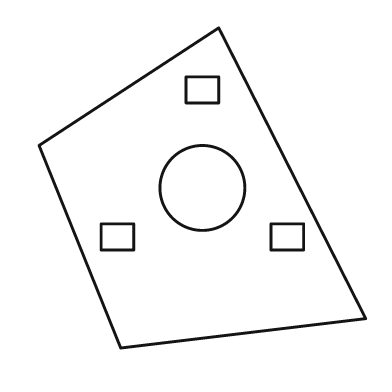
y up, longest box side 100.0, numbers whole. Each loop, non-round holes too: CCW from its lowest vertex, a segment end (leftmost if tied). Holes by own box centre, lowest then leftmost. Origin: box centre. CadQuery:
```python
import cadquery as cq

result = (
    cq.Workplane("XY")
    .moveTo(-25.0, -49.0)
    .lineTo(50.0, -40.0)
    .lineTo(5.0, 49.0)
    .lineTo(-50.0, 13.0)
    .close()
    .moveTo(-31.0, -19.0)
    .lineTo(-21.0, -19.0)
    .lineTo(-21.0, -11.0)
    .lineTo(-31.0, -11.0)
    .close()
    .moveTo(21.0, -19.0)
    .lineTo(31.0, -19.0)
    .lineTo(31.0, -11.0)
    .lineTo(21.0, -11.0)
    .close()
    .moveTo(0.0, 0.0)
    .circle(13.0)
    .moveTo(-5.0, 26.0)
    .lineTo(5.0, 26.0)
    .lineTo(5.0, 34.0)
    .lineTo(-5.0, 34.0)
    .close()
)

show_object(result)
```